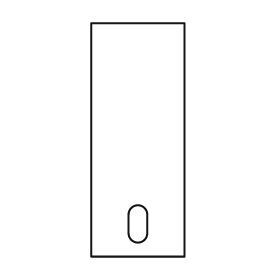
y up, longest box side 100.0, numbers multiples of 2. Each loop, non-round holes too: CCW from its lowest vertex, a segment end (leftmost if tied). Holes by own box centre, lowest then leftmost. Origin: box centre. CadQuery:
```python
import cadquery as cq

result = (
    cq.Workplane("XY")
    .moveTo(-20.0, -50.0)
    .lineTo(20.0, -50.0)
    .lineTo(20.0, 50.0)
    .lineTo(-20.0, 50.0)
    .close()
    .moveTo(-4.0, -40.0)
    .threePointArc((0.0, -44.0), (4.0, -40.0))
    .lineTo(4.0, -32.0)
    .threePointArc((0.0, -28.0), (-4.0, -32.0))
    .close()
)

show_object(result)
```